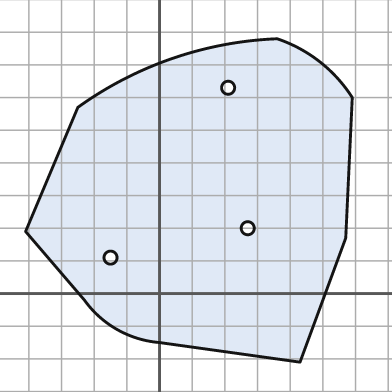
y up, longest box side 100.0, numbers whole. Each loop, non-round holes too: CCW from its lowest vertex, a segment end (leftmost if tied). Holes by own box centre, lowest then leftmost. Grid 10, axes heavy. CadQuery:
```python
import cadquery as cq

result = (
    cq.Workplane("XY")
    .moveTo(43.0, -21.0)
    .lineTo(57.0, 17.0)
    .lineTo(59.0, 60.0)
    .threePointArc((49.0, 71.0), (36.0, 78.0))
    .threePointArc((4.0, 72.0), (-25.0, 57.0))
    .lineTo(-41.0, 19.0)
    .lineTo(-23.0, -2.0)
    .threePointArc((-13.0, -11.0), (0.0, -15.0))
    .close()
    .moveTo(-15.0, 11.0)
    .circle(2.0)
    .moveTo(27.0, 20.0)
    .circle(2.0)
    .moveTo(21.0, 63.0)
    .circle(2.0)
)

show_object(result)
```